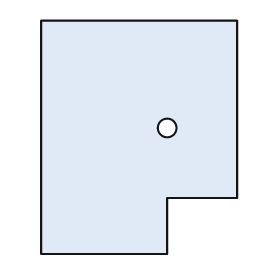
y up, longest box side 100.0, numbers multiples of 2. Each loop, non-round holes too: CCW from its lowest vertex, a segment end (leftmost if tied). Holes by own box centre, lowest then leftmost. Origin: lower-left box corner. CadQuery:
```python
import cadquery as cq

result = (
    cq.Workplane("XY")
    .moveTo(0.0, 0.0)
    .lineTo(54.0, 0.0)
    .lineTo(54.0, 24.0)
    .lineTo(84.0, 24.0)
    .lineTo(84.0, 100.0)
    .lineTo(0.0, 100.0)
    .close()
    .moveTo(54.0, 54.0)
    .circle(4.0)
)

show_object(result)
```